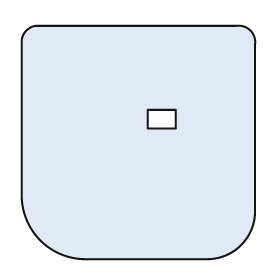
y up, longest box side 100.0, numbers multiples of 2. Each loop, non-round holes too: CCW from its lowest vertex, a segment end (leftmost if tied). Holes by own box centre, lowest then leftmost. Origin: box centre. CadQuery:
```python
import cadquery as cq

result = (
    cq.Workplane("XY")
    .moveTo(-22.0, -50.0)
    .lineTo(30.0, -50.0)
    .threePointArc((44.0, -44.0), (50.0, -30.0))
    .lineTo(50.0, 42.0)
    .threePointArc((48.0, 48.0), (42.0, 50.0))
    .lineTo(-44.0, 50.0)
    .threePointArc((-48.0, 48.0), (-50.0, 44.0))
    .lineTo(-50.0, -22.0)
    .threePointArc((-42.0, -42.0), (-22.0, -50.0))
    .close()
    .moveTo(4.0, 6.0)
    .lineTo(16.0, 6.0)
    .lineTo(16.0, 14.0)
    .lineTo(4.0, 14.0)
    .close()
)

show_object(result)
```